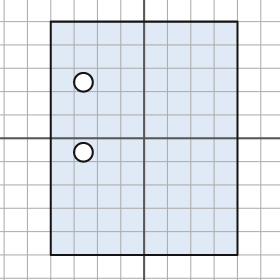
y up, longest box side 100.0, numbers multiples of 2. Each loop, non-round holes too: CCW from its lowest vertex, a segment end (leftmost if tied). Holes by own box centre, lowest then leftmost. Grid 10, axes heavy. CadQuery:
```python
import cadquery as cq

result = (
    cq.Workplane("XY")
    .moveTo(-40.0, -50.0)
    .lineTo(40.0, -50.0)
    .lineTo(40.0, 50.0)
    .lineTo(-40.0, 50.0)
    .close()
    .moveTo(-26.0, -6.0)
    .circle(4.0)
    .moveTo(-26.0, 24.0)
    .circle(4.0)
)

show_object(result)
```